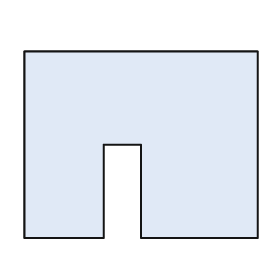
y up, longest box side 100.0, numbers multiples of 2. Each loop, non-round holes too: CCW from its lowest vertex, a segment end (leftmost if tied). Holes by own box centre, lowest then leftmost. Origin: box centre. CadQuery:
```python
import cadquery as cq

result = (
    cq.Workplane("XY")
    .moveTo(-50.0, -40.0)
    .lineTo(-16.0, -40.0)
    .lineTo(-16.0, 0.0)
    .lineTo(0.0, 0.0)
    .lineTo(0.0, -40.0)
    .lineTo(50.0, -40.0)
    .lineTo(50.0, 40.0)
    .lineTo(-50.0, 40.0)
    .close()
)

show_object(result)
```